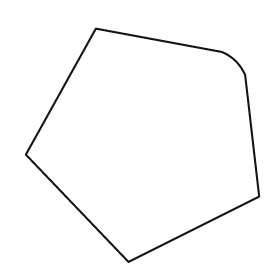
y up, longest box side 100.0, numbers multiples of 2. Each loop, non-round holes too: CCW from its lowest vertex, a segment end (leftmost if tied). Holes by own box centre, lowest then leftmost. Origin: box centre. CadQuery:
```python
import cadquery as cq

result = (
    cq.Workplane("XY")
    .moveTo(-6.0, -50.0)
    .lineTo(50.0, -22.0)
    .lineTo(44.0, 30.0)
    .threePointArc((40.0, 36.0), (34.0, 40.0))
    .lineTo(-20.0, 50.0)
    .lineTo(-50.0, -4.0)
    .close()
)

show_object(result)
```